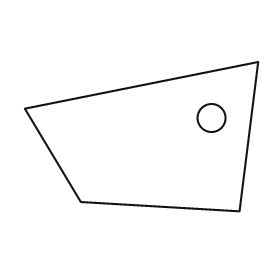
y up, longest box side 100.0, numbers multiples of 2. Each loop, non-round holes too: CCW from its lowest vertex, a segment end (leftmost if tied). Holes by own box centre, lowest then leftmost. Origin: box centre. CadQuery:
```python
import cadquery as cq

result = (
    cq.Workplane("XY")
    .moveTo(42.0, -32.0)
    .lineTo(50.0, 32.0)
    .lineTo(-50.0, 12.0)
    .lineTo(-26.0, -28.0)
    .close()
    .moveTo(30.0, 8.0)
    .circle(6.0)
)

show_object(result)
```